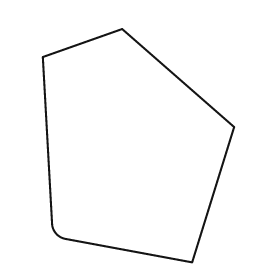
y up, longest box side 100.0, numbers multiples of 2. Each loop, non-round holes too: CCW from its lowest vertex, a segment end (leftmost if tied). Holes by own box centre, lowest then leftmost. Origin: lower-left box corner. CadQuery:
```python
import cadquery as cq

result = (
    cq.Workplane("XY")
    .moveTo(64.0, 0.0)
    .lineTo(82.0, 58.0)
    .lineTo(34.0, 100.0)
    .lineTo(0.0, 88.0)
    .lineTo(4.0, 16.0)
    .threePointArc((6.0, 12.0), (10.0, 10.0))
    .close()
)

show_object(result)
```